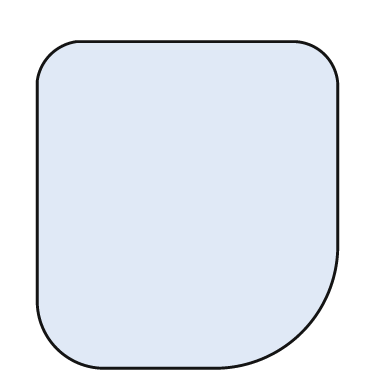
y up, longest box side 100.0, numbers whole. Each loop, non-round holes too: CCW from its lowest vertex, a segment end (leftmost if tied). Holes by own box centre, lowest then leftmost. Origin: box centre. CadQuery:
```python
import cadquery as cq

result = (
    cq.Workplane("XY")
    .moveTo(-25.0, -50.0)
    .lineTo(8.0, -50.0)
    .threePointArc((35.0, -39.0), (46.0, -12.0))
    .lineTo(46.0, 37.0)
    .threePointArc((42.0, 46.0), (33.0, 50.0))
    .lineTo(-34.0, 50.0)
    .threePointArc((-42.0, 46.0), (-46.0, 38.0))
    .lineTo(-46.0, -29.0)
    .threePointArc((-40.0, -44.0), (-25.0, -50.0))
    .close()
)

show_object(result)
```